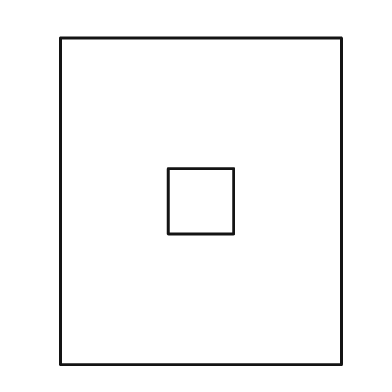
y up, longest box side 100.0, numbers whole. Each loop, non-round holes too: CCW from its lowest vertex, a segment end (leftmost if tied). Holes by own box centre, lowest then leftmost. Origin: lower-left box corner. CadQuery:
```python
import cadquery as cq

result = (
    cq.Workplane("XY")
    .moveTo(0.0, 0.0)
    .lineTo(86.0, 0.0)
    .lineTo(86.0, 100.0)
    .lineTo(0.0, 100.0)
    .close()
    .moveTo(33.0, 40.0)
    .lineTo(53.0, 40.0)
    .lineTo(53.0, 60.0)
    .lineTo(33.0, 60.0)
    .close()
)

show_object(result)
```